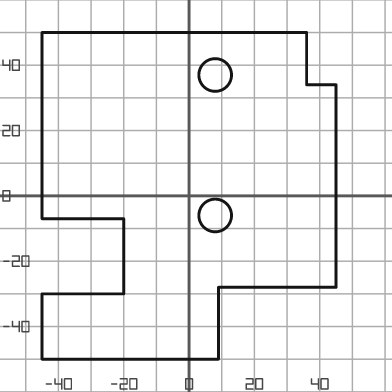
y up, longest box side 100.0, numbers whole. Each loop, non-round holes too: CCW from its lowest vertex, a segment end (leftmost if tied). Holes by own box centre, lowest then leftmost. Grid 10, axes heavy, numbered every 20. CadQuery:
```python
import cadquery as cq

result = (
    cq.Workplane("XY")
    .moveTo(-45.0, -50.0)
    .lineTo(9.0, -50.0)
    .lineTo(9.0, -28.0)
    .lineTo(45.0, -28.0)
    .lineTo(45.0, 34.0)
    .lineTo(36.0, 34.0)
    .lineTo(36.0, 50.0)
    .lineTo(-45.0, 50.0)
    .lineTo(-45.0, -7.0)
    .lineTo(-20.0, -7.0)
    .lineTo(-20.0, -30.0)
    .lineTo(-45.0, -30.0)
    .close()
    .moveTo(8.0, -6.0)
    .circle(5.0)
    .moveTo(8.0, 37.0)
    .circle(5.0)
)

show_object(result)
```